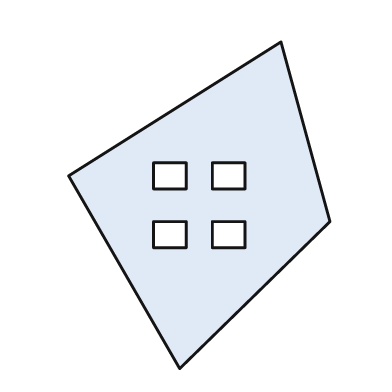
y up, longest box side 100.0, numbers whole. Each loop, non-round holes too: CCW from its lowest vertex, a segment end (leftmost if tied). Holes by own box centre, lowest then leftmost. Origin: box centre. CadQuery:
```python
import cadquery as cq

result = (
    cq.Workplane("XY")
    .moveTo(-6.0, -50.0)
    .lineTo(40.0, -5.0)
    .lineTo(25.0, 50.0)
    .lineTo(-40.0, 9.0)
    .close()
    .moveTo(-14.0, -13.0)
    .lineTo(-4.0, -13.0)
    .lineTo(-4.0, -5.0)
    .lineTo(-14.0, -5.0)
    .close()
    .moveTo(4.0, -13.0)
    .lineTo(14.0, -13.0)
    .lineTo(14.0, -5.0)
    .lineTo(4.0, -5.0)
    .close()
    .moveTo(-14.0, 5.0)
    .lineTo(-4.0, 5.0)
    .lineTo(-4.0, 13.0)
    .lineTo(-14.0, 13.0)
    .close()
    .moveTo(4.0, 5.0)
    .lineTo(14.0, 5.0)
    .lineTo(14.0, 13.0)
    .lineTo(4.0, 13.0)
    .close()
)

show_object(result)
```